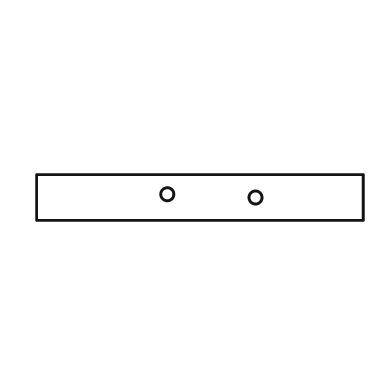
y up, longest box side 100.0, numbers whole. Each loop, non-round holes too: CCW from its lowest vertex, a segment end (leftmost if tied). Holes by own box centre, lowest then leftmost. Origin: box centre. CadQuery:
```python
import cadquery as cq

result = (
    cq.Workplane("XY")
    .moveTo(-50.0, -7.0)
    .lineTo(50.0, -7.0)
    .lineTo(50.0, 7.0)
    .lineTo(-50.0, 7.0)
    .close()
    .moveTo(17.0, 0.0)
    .circle(2.0)
    .moveTo(-10.0, 1.0)
    .circle(2.0)
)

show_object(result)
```